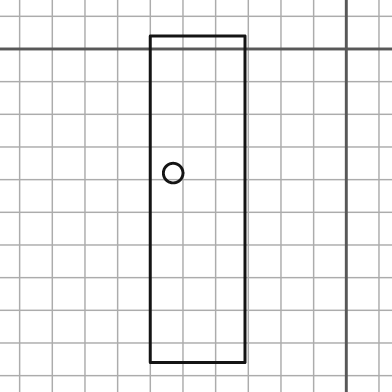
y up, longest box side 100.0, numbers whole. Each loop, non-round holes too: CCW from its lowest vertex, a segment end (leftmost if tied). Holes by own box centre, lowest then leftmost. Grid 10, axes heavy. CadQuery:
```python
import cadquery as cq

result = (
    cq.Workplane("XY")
    .moveTo(-60.0, -96.0)
    .lineTo(-31.0, -96.0)
    .lineTo(-31.0, 4.0)
    .lineTo(-60.0, 4.0)
    .close()
    .moveTo(-53.0, -38.0)
    .circle(3.0)
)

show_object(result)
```